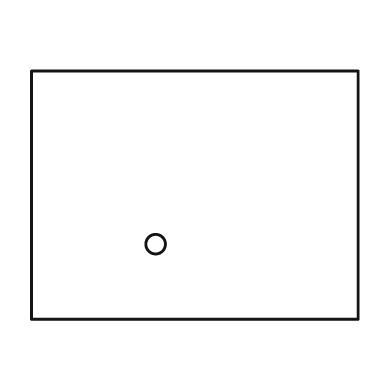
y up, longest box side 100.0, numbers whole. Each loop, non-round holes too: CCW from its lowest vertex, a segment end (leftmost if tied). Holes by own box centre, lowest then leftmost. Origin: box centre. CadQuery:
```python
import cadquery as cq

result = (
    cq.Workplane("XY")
    .moveTo(-50.0, -38.0)
    .lineTo(50.0, -38.0)
    .lineTo(50.0, 38.0)
    .lineTo(-50.0, 38.0)
    .close()
    .moveTo(-12.0, -15.0)
    .circle(3.0)
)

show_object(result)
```